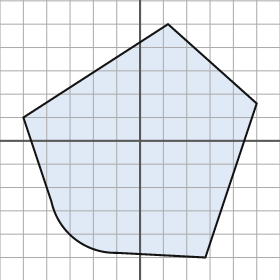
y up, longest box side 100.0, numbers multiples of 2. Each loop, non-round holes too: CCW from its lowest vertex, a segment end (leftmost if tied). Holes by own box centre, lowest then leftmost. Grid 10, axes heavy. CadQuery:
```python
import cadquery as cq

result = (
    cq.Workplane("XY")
    .moveTo(28.0, -50.0)
    .lineTo(50.0, 16.0)
    .lineTo(12.0, 50.0)
    .lineTo(-50.0, 10.0)
    .lineTo(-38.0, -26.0)
    .threePointArc((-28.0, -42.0), (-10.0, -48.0))
    .close()
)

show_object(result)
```